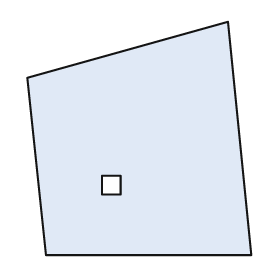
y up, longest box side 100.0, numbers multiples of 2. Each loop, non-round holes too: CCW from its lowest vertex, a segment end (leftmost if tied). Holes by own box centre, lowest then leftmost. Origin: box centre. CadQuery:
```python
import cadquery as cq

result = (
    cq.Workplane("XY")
    .moveTo(-40.0, -50.0)
    .lineTo(48.0, -50.0)
    .lineTo(38.0, 50.0)
    .lineTo(-48.0, 26.0)
    .close()
    .moveTo(-16.0, -24.0)
    .lineTo(-8.0, -24.0)
    .lineTo(-8.0, -16.0)
    .lineTo(-16.0, -16.0)
    .close()
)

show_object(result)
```